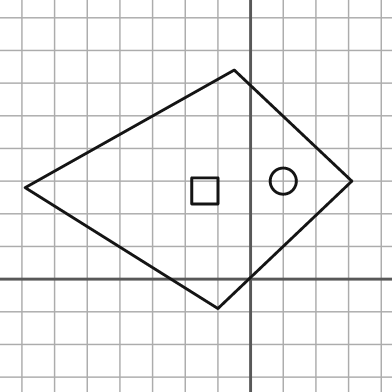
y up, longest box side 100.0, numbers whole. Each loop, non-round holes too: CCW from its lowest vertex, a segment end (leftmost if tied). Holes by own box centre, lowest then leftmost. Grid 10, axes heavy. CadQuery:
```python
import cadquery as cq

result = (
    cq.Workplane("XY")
    .moveTo(-10.0, -9.0)
    .lineTo(31.0, 30.0)
    .lineTo(-5.0, 64.0)
    .lineTo(-69.0, 28.0)
    .close()
    .moveTo(-18.0, 23.0)
    .lineTo(-10.0, 23.0)
    .lineTo(-10.0, 31.0)
    .lineTo(-18.0, 31.0)
    .close()
    .moveTo(10.0, 30.0)
    .circle(4.0)
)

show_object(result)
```